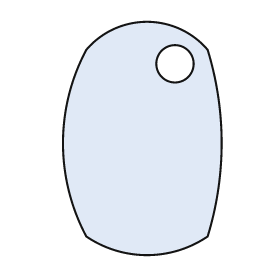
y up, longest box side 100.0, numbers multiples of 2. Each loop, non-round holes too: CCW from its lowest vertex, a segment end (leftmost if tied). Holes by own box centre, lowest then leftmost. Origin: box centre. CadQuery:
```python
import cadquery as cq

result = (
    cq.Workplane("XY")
    .moveTo(-24.0, -42.0)
    .threePointArc((2.0, -50.0), (28.0, -42.0))
    .threePointArc((34.0, -2.0), (28.0, 38.0))
    .threePointArc((2.0, 50.0), (-24.0, 38.0))
    .threePointArc((-34.0, -2.0), (-24.0, -42.0))
    .close()
    .moveTo(14.0, 32.0)
    .circle(8.0)
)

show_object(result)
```